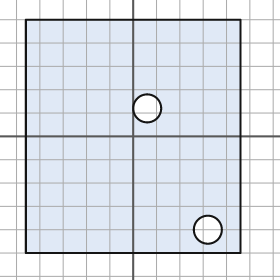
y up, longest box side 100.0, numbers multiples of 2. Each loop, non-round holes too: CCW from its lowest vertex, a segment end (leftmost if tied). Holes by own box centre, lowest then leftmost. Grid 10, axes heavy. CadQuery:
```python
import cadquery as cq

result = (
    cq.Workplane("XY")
    .moveTo(-46.0, -50.0)
    .lineTo(46.0, -50.0)
    .lineTo(46.0, 50.0)
    .lineTo(-46.0, 50.0)
    .close()
    .moveTo(32.0, -40.0)
    .circle(6.0)
    .moveTo(6.0, 12.0)
    .circle(6.0)
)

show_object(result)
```